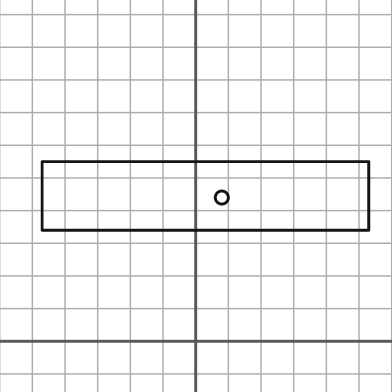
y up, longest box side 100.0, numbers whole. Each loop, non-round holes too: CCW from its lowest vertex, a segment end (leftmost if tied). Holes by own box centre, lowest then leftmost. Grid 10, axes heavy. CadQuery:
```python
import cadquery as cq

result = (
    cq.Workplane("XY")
    .moveTo(-47.0, 34.0)
    .lineTo(53.0, 34.0)
    .lineTo(53.0, 55.0)
    .lineTo(-47.0, 55.0)
    .close()
    .moveTo(8.0, 44.0)
    .circle(2.0)
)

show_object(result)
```